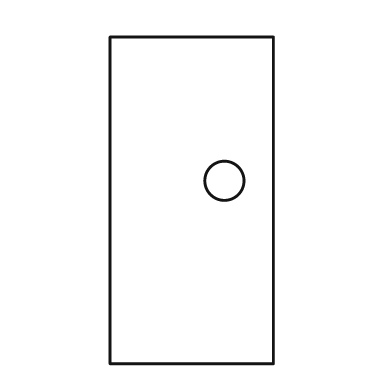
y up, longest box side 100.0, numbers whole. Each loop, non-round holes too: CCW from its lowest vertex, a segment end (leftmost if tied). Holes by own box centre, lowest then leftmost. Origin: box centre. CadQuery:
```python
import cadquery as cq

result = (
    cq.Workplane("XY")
    .moveTo(-25.0, -50.0)
    .lineTo(25.0, -50.0)
    .lineTo(25.0, 50.0)
    .lineTo(-25.0, 50.0)
    .close()
    .moveTo(10.0, 6.0)
    .circle(6.0)
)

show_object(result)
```